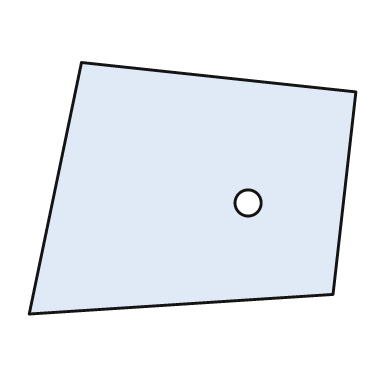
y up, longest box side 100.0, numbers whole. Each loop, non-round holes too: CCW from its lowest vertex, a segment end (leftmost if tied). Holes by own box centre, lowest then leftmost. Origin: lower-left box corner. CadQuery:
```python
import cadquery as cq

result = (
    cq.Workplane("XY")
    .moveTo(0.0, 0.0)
    .lineTo(93.0, 6.0)
    .lineTo(100.0, 68.0)
    .lineTo(16.0, 77.0)
    .close()
    .moveTo(67.0, 34.0)
    .circle(4.0)
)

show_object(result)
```